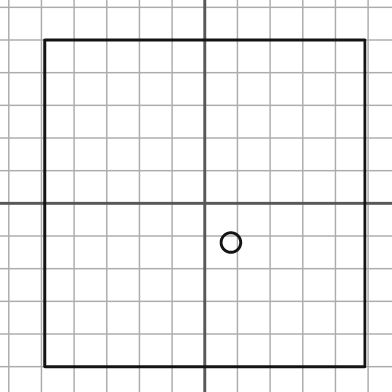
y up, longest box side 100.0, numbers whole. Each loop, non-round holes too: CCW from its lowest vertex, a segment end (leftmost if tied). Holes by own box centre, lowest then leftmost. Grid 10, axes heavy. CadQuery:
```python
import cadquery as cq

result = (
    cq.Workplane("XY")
    .moveTo(-49.0, -50.0)
    .lineTo(49.0, -50.0)
    .lineTo(49.0, 50.0)
    .lineTo(-49.0, 50.0)
    .close()
    .moveTo(8.0, -12.0)
    .circle(3.0)
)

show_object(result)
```